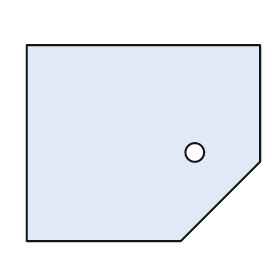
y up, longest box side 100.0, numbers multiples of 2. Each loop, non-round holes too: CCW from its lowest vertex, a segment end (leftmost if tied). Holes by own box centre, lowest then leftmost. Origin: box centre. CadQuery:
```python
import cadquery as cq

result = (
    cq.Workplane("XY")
    .moveTo(-50.0, -42.0)
    .lineTo(16.0, -42.0)
    .lineTo(50.0, -8.0)
    .lineTo(50.0, 42.0)
    .lineTo(-50.0, 42.0)
    .close()
    .moveTo(22.0, -4.0)
    .circle(4.0)
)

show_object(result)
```